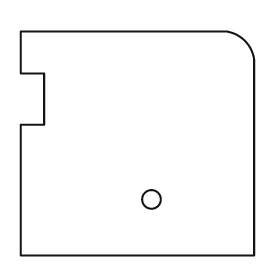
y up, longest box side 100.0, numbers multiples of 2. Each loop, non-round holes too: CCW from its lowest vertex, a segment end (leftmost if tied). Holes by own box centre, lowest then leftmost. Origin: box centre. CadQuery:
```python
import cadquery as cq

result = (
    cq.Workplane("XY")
    .moveTo(-50.0, -48.0)
    .lineTo(50.0, -48.0)
    .lineTo(50.0, 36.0)
    .threePointArc((46.0, 44.0), (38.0, 48.0))
    .lineTo(-50.0, 48.0)
    .lineTo(-50.0, 30.0)
    .lineTo(-40.0, 30.0)
    .lineTo(-40.0, 8.0)
    .lineTo(-50.0, 8.0)
    .close()
    .moveTo(6.0, -24.0)
    .circle(4.0)
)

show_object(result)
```